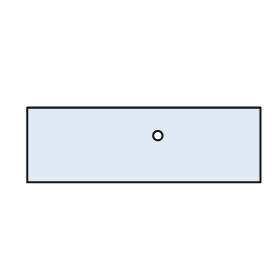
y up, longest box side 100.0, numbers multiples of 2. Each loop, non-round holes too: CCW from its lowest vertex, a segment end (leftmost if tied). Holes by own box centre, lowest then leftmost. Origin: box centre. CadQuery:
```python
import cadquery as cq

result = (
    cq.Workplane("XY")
    .moveTo(-50.0, -16.0)
    .lineTo(50.0, -16.0)
    .lineTo(50.0, 16.0)
    .lineTo(-50.0, 16.0)
    .close()
    .moveTo(6.0, 4.0)
    .circle(2.0)
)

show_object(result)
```